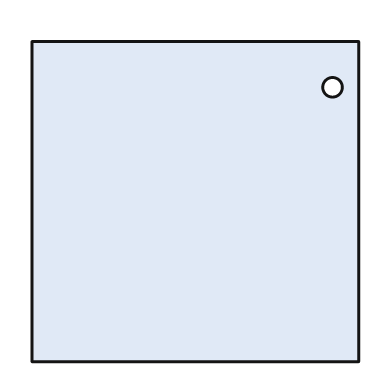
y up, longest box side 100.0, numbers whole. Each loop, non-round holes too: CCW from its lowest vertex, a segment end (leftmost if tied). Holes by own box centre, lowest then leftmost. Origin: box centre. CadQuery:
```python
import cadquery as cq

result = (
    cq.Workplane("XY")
    .moveTo(-50.0, -49.0)
    .lineTo(50.0, -49.0)
    .lineTo(50.0, 49.0)
    .lineTo(-50.0, 49.0)
    .close()
    .moveTo(42.0, 35.0)
    .circle(3.0)
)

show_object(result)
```